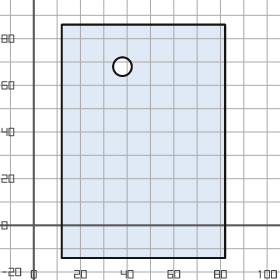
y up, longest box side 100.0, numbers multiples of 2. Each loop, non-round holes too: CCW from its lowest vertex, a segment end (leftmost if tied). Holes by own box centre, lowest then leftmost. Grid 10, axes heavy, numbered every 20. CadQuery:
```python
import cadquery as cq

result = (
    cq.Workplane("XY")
    .moveTo(12.0, -14.0)
    .lineTo(82.0, -14.0)
    .lineTo(82.0, 86.0)
    .lineTo(12.0, 86.0)
    .close()
    .moveTo(38.0, 68.0)
    .circle(4.0)
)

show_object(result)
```